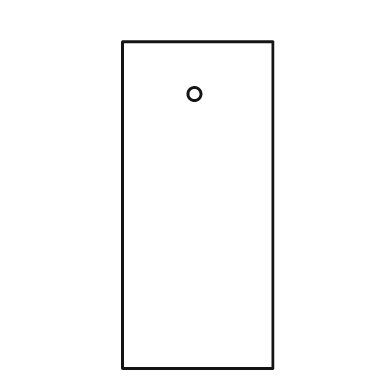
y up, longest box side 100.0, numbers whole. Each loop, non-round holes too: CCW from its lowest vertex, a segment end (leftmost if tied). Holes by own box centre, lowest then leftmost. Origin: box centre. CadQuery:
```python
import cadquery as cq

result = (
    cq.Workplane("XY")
    .moveTo(-23.0, -50.0)
    .lineTo(23.0, -50.0)
    .lineTo(23.0, 50.0)
    .lineTo(-23.0, 50.0)
    .close()
    .moveTo(-1.0, 34.0)
    .circle(2.0)
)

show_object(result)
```